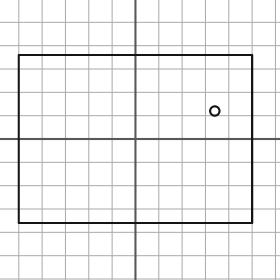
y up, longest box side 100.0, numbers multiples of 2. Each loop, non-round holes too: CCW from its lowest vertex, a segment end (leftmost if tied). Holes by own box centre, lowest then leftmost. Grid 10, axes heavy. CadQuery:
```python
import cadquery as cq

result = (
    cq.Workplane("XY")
    .moveTo(-50.0, -36.0)
    .lineTo(50.0, -36.0)
    .lineTo(50.0, 36.0)
    .lineTo(-50.0, 36.0)
    .close()
    .moveTo(34.0, 12.0)
    .circle(2.0)
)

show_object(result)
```